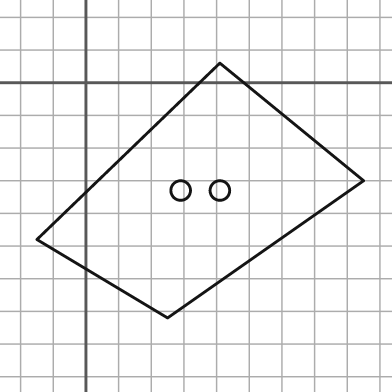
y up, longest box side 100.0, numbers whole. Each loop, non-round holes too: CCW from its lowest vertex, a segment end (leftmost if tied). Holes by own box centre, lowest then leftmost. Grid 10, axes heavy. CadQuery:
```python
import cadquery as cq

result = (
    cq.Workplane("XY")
    .moveTo(25.0, -72.0)
    .lineTo(85.0, -30.0)
    .lineTo(41.0, 6.0)
    .lineTo(-15.0, -48.0)
    .close()
    .moveTo(29.0, -33.0)
    .circle(3.0)
    .moveTo(41.0, -33.0)
    .circle(3.0)
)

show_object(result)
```